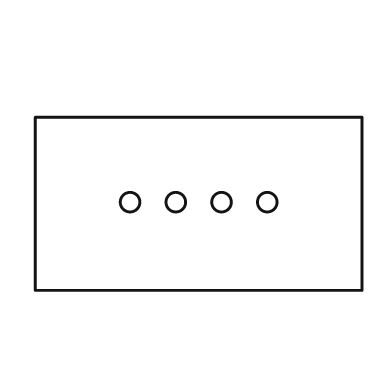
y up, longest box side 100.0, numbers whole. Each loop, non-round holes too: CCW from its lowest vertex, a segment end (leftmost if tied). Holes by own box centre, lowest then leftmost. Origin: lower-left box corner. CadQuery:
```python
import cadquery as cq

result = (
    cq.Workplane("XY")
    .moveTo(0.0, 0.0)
    .lineTo(100.0, 0.0)
    .lineTo(100.0, 53.0)
    .lineTo(0.0, 53.0)
    .close()
    .moveTo(29.0, 27.0)
    .circle(3.0)
    .moveTo(43.0, 27.0)
    .circle(3.0)
    .moveTo(57.0, 27.0)
    .circle(3.0)
    .moveTo(71.0, 27.0)
    .circle(3.0)
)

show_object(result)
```